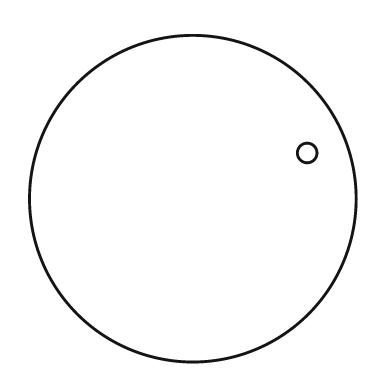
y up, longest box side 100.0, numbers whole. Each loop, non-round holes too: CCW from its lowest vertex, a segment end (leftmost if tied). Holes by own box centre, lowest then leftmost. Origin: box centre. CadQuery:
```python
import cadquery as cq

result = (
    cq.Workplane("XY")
    .moveTo(0.0, 0.0)
    .circle(50.0)
    .moveTo(35.0, 14.0)
    .circle(3.0)
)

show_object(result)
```